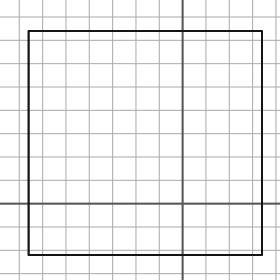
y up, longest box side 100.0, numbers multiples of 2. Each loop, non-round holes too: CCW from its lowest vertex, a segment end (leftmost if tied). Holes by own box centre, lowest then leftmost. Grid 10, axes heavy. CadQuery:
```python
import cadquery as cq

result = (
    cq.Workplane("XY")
    .moveTo(-66.0, -22.0)
    .lineTo(34.0, -22.0)
    .lineTo(34.0, 74.0)
    .lineTo(-66.0, 74.0)
    .close()
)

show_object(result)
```